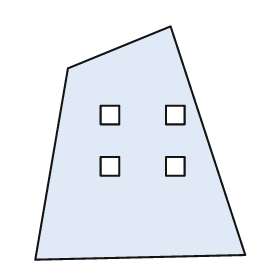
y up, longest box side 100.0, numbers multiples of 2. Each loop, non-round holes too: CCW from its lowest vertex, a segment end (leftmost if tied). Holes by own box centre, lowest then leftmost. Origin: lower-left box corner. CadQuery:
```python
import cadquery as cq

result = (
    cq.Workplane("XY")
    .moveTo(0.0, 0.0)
    .lineTo(90.0, 2.0)
    .lineTo(58.0, 100.0)
    .lineTo(14.0, 82.0)
    .close()
    .moveTo(28.0, 36.0)
    .lineTo(36.0, 36.0)
    .lineTo(36.0, 44.0)
    .lineTo(28.0, 44.0)
    .close()
    .moveTo(56.0, 36.0)
    .lineTo(64.0, 36.0)
    .lineTo(64.0, 44.0)
    .lineTo(56.0, 44.0)
    .close()
    .moveTo(28.0, 58.0)
    .lineTo(36.0, 58.0)
    .lineTo(36.0, 66.0)
    .lineTo(28.0, 66.0)
    .close()
    .moveTo(56.0, 58.0)
    .lineTo(64.0, 58.0)
    .lineTo(64.0, 66.0)
    .lineTo(56.0, 66.0)
    .close()
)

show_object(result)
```